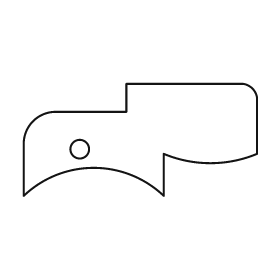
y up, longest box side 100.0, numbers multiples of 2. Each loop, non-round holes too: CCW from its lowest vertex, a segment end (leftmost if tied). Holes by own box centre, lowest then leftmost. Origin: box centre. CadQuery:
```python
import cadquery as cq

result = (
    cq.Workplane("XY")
    .moveTo(-50.0, -24.0)
    .threePointArc((-20.0, -12.0), (10.0, -24.0))
    .lineTo(10.0, -6.0)
    .threePointArc((30.0, -10.0), (50.0, -6.0))
    .lineTo(50.0, 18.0)
    .threePointArc((48.0, 22.0), (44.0, 24.0))
    .lineTo(-6.0, 24.0)
    .lineTo(-6.0, 12.0)
    .lineTo(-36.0, 12.0)
    .threePointArc((-46.0, 8.0), (-50.0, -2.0))
    .close()
    .moveTo(-26.0, -4.0)
    .circle(4.0)
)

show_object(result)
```